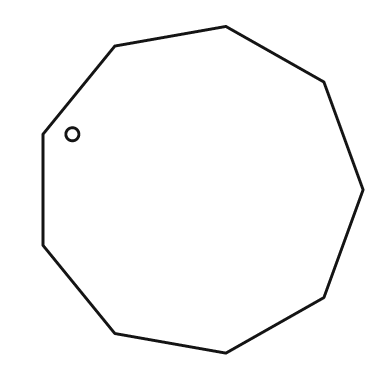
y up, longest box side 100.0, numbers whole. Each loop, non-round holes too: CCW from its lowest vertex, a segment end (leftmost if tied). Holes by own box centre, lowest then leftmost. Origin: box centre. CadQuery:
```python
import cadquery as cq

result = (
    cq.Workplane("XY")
    .moveTo(7.0, -50.0)
    .lineTo(37.0, -33.0)
    .lineTo(49.0, 0.0)
    .lineTo(37.0, 33.0)
    .lineTo(7.0, 50.0)
    .lineTo(-27.0, 44.0)
    .lineTo(-49.0, 17.0)
    .lineTo(-49.0, -17.0)
    .lineTo(-27.0, -44.0)
    .close()
    .moveTo(-40.0, 17.0)
    .circle(2.0)
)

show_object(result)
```